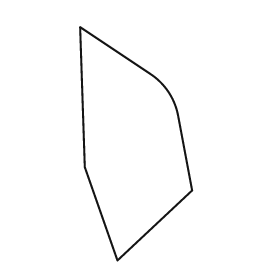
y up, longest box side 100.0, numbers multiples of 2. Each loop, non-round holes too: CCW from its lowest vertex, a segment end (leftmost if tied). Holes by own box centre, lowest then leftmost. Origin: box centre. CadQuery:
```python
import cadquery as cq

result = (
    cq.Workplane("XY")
    .moveTo(-8.0, -50.0)
    .lineTo(24.0, -20.0)
    .lineTo(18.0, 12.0)
    .threePointArc((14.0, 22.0), (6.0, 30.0))
    .lineTo(-24.0, 50.0)
    .lineTo(-22.0, -10.0)
    .close()
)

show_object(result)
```